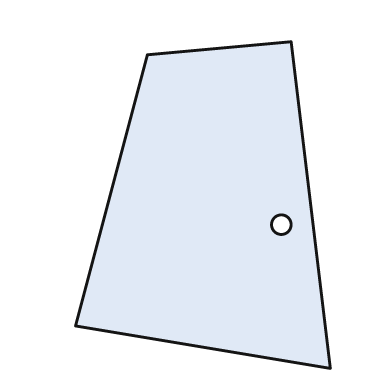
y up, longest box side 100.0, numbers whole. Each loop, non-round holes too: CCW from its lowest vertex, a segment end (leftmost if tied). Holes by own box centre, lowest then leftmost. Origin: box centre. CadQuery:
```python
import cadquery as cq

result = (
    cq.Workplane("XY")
    .moveTo(39.0, -50.0)
    .lineTo(27.0, 50.0)
    .lineTo(-17.0, 46.0)
    .lineTo(-39.0, -37.0)
    .close()
    .moveTo(24.0, -6.0)
    .circle(3.0)
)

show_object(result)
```